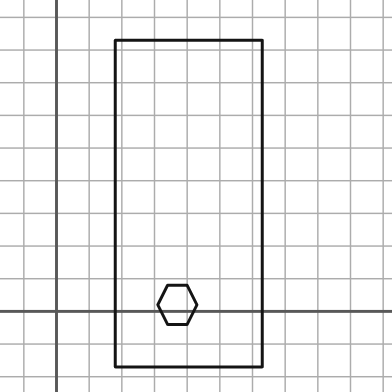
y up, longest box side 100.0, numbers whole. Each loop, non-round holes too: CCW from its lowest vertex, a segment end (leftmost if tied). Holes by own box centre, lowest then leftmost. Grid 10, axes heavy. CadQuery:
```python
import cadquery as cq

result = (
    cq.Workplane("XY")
    .moveTo(18.0, -17.0)
    .lineTo(63.0, -17.0)
    .lineTo(63.0, 83.0)
    .lineTo(18.0, 83.0)
    .close()
    .moveTo(34.0, -4.0)
    .lineTo(40.0, -4.0)
    .lineTo(43.0, 2.0)
    .lineTo(40.0, 8.0)
    .lineTo(34.0, 8.0)
    .lineTo(31.0, 2.0)
    .close()
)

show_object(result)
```